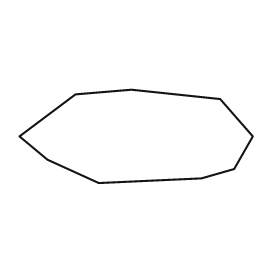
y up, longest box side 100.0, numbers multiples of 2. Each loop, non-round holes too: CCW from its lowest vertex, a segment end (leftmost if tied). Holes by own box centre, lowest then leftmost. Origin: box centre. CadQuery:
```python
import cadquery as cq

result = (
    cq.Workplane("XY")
    .moveTo(-16.0, -20.0)
    .lineTo(28.0, -18.0)
    .lineTo(42.0, -14.0)
    .lineTo(50.0, 0.0)
    .lineTo(36.0, 16.0)
    .lineTo(-2.0, 20.0)
    .lineTo(-26.0, 18.0)
    .lineTo(-50.0, 0.0)
    .lineTo(-38.0, -10.0)
    .close()
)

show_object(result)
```